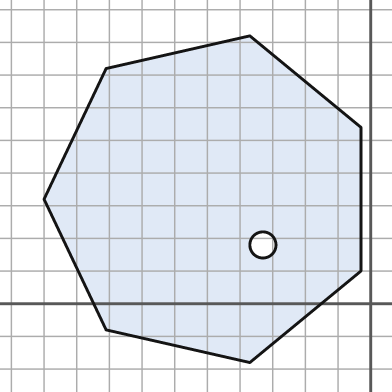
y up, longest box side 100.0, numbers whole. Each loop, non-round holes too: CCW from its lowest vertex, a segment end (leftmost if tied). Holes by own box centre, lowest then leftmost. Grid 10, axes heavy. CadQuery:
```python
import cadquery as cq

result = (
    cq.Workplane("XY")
    .moveTo(-37.0, -18.0)
    .lineTo(-3.0, 10.0)
    .lineTo(-3.0, 54.0)
    .lineTo(-37.0, 82.0)
    .lineTo(-81.0, 72.0)
    .lineTo(-100.0, 32.0)
    .lineTo(-81.0, -8.0)
    .close()
    .moveTo(-33.0, 18.0)
    .circle(4.0)
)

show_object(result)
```